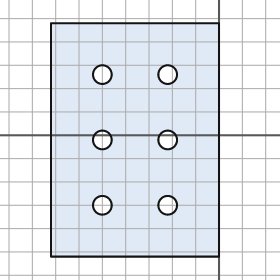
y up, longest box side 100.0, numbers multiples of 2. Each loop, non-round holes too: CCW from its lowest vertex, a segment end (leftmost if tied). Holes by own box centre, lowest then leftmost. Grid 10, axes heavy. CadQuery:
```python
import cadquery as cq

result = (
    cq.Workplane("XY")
    .moveTo(-72.0, -52.0)
    .lineTo(0.0, -52.0)
    .lineTo(0.0, 48.0)
    .lineTo(-72.0, 48.0)
    .close()
    .moveTo(-50.0, -30.0)
    .circle(4.0)
    .moveTo(-22.0, -30.0)
    .circle(4.0)
    .moveTo(-50.0, -2.0)
    .circle(4.0)
    .moveTo(-22.0, -2.0)
    .circle(4.0)
    .moveTo(-50.0, 26.0)
    .circle(4.0)
    .moveTo(-22.0, 26.0)
    .circle(4.0)
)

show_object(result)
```